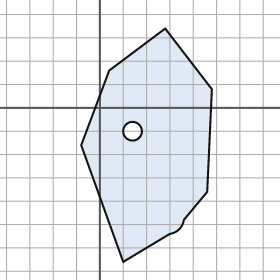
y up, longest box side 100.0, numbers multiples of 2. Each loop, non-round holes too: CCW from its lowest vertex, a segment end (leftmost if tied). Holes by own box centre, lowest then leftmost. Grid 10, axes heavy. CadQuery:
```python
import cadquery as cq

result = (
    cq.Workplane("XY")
    .moveTo(10.0, -66.0)
    .lineTo(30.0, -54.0)
    .threePointArc((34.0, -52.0), (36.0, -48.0))
    .lineTo(46.0, -36.0)
    .lineTo(48.0, 8.0)
    .lineTo(28.0, 34.0)
    .lineTo(4.0, 16.0)
    .lineTo(-8.0, -16.0)
    .close()
    .moveTo(14.0, -10.0)
    .circle(4.0)
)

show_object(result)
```